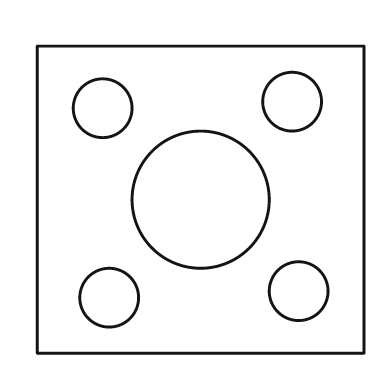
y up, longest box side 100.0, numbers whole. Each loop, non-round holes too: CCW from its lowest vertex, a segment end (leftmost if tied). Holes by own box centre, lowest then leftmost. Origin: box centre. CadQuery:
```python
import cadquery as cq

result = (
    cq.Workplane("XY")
    .moveTo(-50.0, -47.0)
    .lineTo(50.0, -47.0)
    .lineTo(50.0, 47.0)
    .lineTo(-50.0, 47.0)
    .close()
    .moveTo(-28.0, -30.0)
    .circle(9.0)
    .moveTo(30.0, -28.0)
    .circle(9.0)
    .moveTo(0.0, 0.0)
    .circle(21.0)
    .moveTo(-30.0, 28.0)
    .circle(9.0)
    .moveTo(28.0, 30.0)
    .circle(9.0)
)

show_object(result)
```